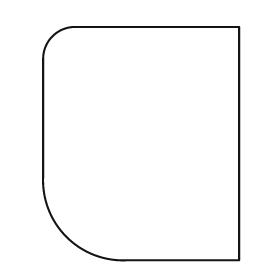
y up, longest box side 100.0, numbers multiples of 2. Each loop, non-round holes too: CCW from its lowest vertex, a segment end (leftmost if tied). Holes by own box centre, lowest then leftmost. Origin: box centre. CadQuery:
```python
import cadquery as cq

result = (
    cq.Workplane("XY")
    .moveTo(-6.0, -50.0)
    .lineTo(42.0, -50.0)
    .lineTo(42.0, 50.0)
    .lineTo(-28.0, 50.0)
    .threePointArc((-38.0, 46.0), (-42.0, 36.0))
    .lineTo(-42.0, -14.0)
    .threePointArc((-32.0, -40.0), (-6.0, -50.0))
    .close()
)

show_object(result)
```